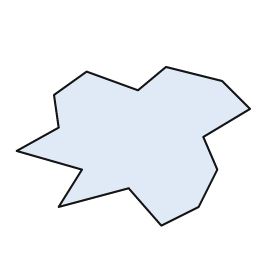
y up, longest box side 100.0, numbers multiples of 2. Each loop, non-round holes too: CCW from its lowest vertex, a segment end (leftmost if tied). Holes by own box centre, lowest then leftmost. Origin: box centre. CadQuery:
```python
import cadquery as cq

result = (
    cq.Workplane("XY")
    .moveTo(12.0, -34.0)
    .lineTo(28.0, -26.0)
    .lineTo(36.0, -10.0)
    .lineTo(30.0, 4.0)
    .lineTo(50.0, 16.0)
    .lineTo(38.0, 28.0)
    .lineTo(14.0, 34.0)
    .lineTo(2.0, 24.0)
    .lineTo(-20.0, 32.0)
    .lineTo(-34.0, 22.0)
    .lineTo(-32.0, 8.0)
    .lineTo(-50.0, -2.0)
    .lineTo(-22.0, -10.0)
    .lineTo(-32.0, -26.0)
    .lineTo(-2.0, -18.0)
    .close()
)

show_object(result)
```